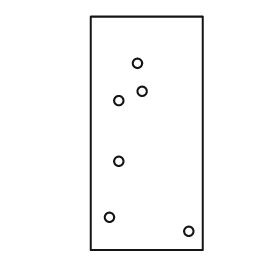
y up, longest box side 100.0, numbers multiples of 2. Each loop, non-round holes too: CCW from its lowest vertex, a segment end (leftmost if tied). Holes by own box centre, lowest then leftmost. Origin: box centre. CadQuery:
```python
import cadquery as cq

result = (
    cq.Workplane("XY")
    .moveTo(-24.0, -50.0)
    .lineTo(24.0, -50.0)
    .lineTo(24.0, 50.0)
    .lineTo(-24.0, 50.0)
    .close()
    .moveTo(18.0, -42.0)
    .circle(2.0)
    .moveTo(-16.0, -36.0)
    .circle(2.0)
    .moveTo(-12.0, -12.0)
    .circle(2.0)
    .moveTo(-12.0, 14.0)
    .circle(2.0)
    .moveTo(-2.0, 18.0)
    .circle(2.0)
    .moveTo(-4.0, 30.0)
    .circle(2.0)
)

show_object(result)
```